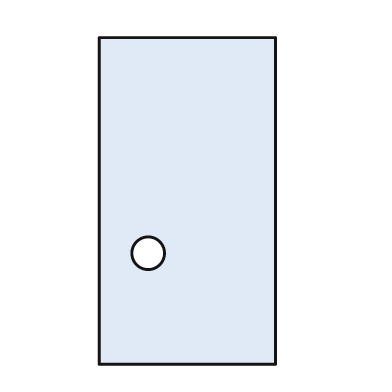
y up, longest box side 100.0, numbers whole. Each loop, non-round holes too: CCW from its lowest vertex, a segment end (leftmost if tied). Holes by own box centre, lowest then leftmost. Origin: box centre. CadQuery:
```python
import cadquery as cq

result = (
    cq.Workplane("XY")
    .moveTo(-27.0, -50.0)
    .lineTo(27.0, -50.0)
    .lineTo(27.0, 50.0)
    .lineTo(-27.0, 50.0)
    .close()
    .moveTo(-12.0, -16.0)
    .circle(5.0)
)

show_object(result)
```